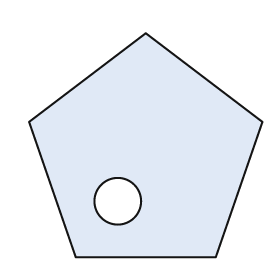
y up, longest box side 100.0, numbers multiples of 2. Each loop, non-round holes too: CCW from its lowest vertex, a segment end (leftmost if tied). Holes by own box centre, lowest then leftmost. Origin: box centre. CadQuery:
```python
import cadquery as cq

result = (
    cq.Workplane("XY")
    .moveTo(-30.0, -48.0)
    .lineTo(30.0, -48.0)
    .lineTo(50.0, 10.0)
    .lineTo(0.0, 48.0)
    .lineTo(-50.0, 10.0)
    .close()
    .moveTo(-12.0, -24.0)
    .circle(10.0)
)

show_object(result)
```